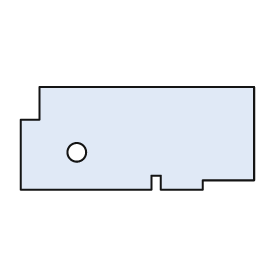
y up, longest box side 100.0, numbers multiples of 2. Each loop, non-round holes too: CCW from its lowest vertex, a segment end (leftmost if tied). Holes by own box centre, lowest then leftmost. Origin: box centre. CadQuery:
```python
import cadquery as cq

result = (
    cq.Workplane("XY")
    .moveTo(-50.0, -22.0)
    .lineTo(6.0, -22.0)
    .lineTo(6.0, -16.0)
    .lineTo(10.0, -16.0)
    .lineTo(10.0, -22.0)
    .lineTo(28.0, -22.0)
    .lineTo(28.0, -18.0)
    .lineTo(50.0, -18.0)
    .lineTo(50.0, 22.0)
    .lineTo(-42.0, 22.0)
    .lineTo(-42.0, 8.0)
    .lineTo(-50.0, 8.0)
    .close()
    .moveTo(-26.0, -6.0)
    .circle(4.0)
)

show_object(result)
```